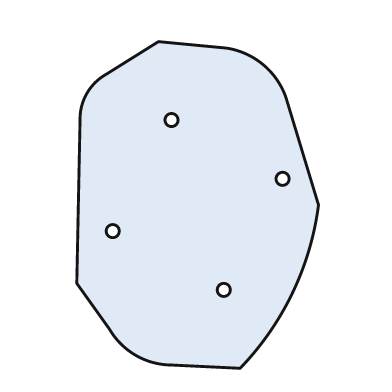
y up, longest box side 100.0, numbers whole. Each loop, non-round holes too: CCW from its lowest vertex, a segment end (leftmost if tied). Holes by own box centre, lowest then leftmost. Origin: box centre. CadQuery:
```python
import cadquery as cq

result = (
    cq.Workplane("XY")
    .moveTo(13.0, -50.0)
    .threePointArc((29.0, -27.0), (37.0, 0.0))
    .lineTo(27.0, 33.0)
    .threePointArc((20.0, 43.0), (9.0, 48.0))
    .lineTo(-12.0, 50.0)
    .lineTo(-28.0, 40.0)
    .threePointArc((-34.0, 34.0), (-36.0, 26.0))
    .lineTo(-37.0, -24.0)
    .lineTo(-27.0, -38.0)
    .threePointArc((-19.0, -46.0), (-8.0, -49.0))
    .close()
    .moveTo(8.0, -26.0)
    .circle(2.0)
    .moveTo(-26.0, -8.0)
    .circle(2.0)
    .moveTo(26.0, 8.0)
    .circle(2.0)
    .moveTo(-8.0, 26.0)
    .circle(2.0)
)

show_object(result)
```